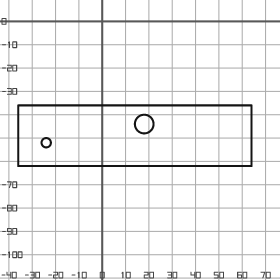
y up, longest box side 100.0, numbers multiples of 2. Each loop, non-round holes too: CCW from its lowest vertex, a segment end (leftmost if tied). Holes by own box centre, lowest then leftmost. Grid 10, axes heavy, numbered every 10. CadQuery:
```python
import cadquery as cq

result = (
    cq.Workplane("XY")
    .moveTo(-36.0, -62.0)
    .lineTo(64.0, -62.0)
    .lineTo(64.0, -36.0)
    .lineTo(-36.0, -36.0)
    .close()
    .moveTo(-24.0, -52.0)
    .circle(2.0)
    .moveTo(18.0, -44.0)
    .circle(4.0)
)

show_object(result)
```